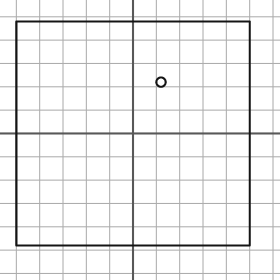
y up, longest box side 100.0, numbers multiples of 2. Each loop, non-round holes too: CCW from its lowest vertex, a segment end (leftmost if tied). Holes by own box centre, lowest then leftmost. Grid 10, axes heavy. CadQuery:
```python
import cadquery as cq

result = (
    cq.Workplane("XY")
    .moveTo(-50.0, -48.0)
    .lineTo(50.0, -48.0)
    .lineTo(50.0, 48.0)
    .lineTo(-50.0, 48.0)
    .close()
    .moveTo(12.0, 22.0)
    .circle(2.0)
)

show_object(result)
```